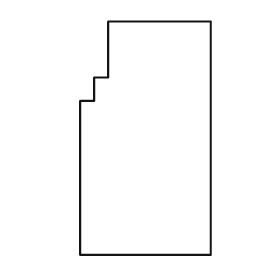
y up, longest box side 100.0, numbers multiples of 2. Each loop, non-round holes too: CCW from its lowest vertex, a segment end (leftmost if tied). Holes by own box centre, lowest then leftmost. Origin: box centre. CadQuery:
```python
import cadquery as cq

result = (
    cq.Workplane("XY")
    .moveTo(-28.0, -50.0)
    .lineTo(28.0, -50.0)
    .lineTo(28.0, 50.0)
    .lineTo(-16.0, 50.0)
    .lineTo(-16.0, 26.0)
    .lineTo(-22.0, 26.0)
    .lineTo(-22.0, 16.0)
    .lineTo(-28.0, 16.0)
    .close()
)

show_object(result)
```